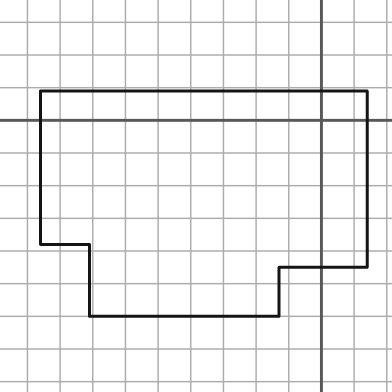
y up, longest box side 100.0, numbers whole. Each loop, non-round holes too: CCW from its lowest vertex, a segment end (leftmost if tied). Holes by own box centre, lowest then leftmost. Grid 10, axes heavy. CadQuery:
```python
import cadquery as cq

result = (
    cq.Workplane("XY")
    .moveTo(-71.0, -60.0)
    .lineTo(-13.0, -60.0)
    .lineTo(-13.0, -45.0)
    .lineTo(14.0, -45.0)
    .lineTo(14.0, 9.0)
    .lineTo(-86.0, 9.0)
    .lineTo(-86.0, -38.0)
    .lineTo(-71.0, -38.0)
    .close()
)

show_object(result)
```